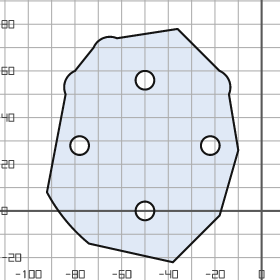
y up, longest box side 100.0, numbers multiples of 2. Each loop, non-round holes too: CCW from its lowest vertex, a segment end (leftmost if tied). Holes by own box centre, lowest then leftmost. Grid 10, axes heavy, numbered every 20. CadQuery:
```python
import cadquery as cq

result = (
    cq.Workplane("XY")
    .moveTo(-38.0, -22.0)
    .lineTo(-18.0, -2.0)
    .lineTo(-10.0, 26.0)
    .lineTo(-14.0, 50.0)
    .threePointArc((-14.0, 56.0), (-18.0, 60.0))
    .lineTo(-36.0, 78.0)
    .lineTo(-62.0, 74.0)
    .threePointArc((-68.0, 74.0), (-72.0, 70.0))
    .lineTo(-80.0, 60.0)
    .threePointArc((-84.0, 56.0), (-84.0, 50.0))
    .lineTo(-92.0, 8.0)
    .threePointArc((-84.0, -4.0), (-74.0, -14.0))
    .close()
    .moveTo(-50.0, 0.0)
    .circle(4.0)
    .moveTo(-78.0, 28.0)
    .circle(4.0)
    .moveTo(-22.0, 28.0)
    .circle(4.0)
    .moveTo(-50.0, 56.0)
    .circle(4.0)
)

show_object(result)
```